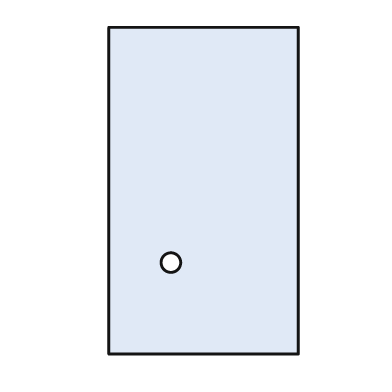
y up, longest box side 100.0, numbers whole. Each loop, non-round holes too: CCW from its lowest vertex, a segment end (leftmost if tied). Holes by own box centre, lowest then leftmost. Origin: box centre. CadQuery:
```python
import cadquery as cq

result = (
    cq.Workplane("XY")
    .moveTo(-29.0, -50.0)
    .lineTo(29.0, -50.0)
    .lineTo(29.0, 50.0)
    .lineTo(-29.0, 50.0)
    .close()
    .moveTo(-10.0, -22.0)
    .circle(3.0)
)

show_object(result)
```